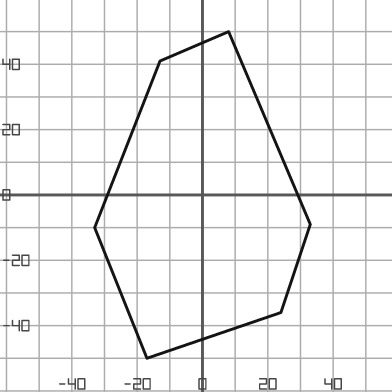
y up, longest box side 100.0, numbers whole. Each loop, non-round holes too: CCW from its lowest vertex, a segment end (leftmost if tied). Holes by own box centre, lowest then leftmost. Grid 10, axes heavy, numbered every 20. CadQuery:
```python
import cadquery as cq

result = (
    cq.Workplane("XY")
    .moveTo(-17.0, -50.0)
    .lineTo(24.0, -36.0)
    .lineTo(33.0, -9.0)
    .lineTo(8.0, 50.0)
    .lineTo(-13.0, 41.0)
    .lineTo(-33.0, -10.0)
    .close()
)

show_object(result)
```